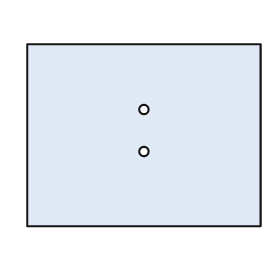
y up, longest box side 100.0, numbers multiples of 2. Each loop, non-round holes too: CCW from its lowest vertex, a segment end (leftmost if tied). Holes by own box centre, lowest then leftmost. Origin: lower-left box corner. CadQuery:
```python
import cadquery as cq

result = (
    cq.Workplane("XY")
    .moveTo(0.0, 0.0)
    .lineTo(100.0, 0.0)
    .lineTo(100.0, 78.0)
    .lineTo(0.0, 78.0)
    .close()
    .moveTo(50.0, 32.0)
    .circle(2.0)
    .moveTo(50.0, 50.0)
    .circle(2.0)
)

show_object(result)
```